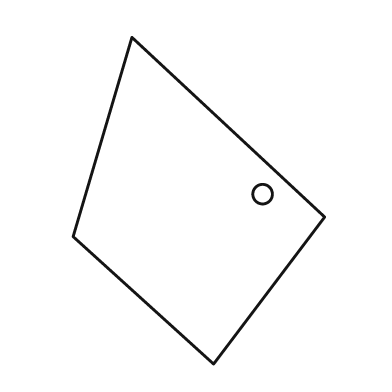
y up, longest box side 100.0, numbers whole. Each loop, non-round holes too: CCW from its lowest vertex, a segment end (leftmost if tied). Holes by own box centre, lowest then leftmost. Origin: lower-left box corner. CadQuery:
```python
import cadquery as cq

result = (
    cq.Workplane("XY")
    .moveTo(43.0, 0.0)
    .lineTo(77.0, 45.0)
    .lineTo(18.0, 100.0)
    .lineTo(0.0, 39.0)
    .close()
    .moveTo(58.0, 52.0)
    .circle(3.0)
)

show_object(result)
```